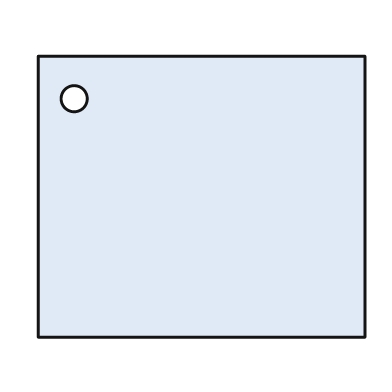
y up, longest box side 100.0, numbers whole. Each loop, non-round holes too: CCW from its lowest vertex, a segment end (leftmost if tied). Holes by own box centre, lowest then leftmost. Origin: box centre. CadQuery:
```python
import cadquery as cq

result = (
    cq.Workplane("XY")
    .moveTo(-50.0, -43.0)
    .lineTo(50.0, -43.0)
    .lineTo(50.0, 43.0)
    .lineTo(-50.0, 43.0)
    .close()
    .moveTo(-39.0, 30.0)
    .circle(4.0)
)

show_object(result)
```